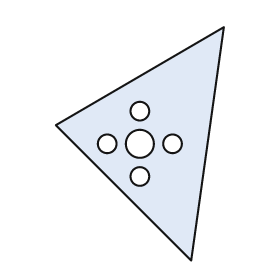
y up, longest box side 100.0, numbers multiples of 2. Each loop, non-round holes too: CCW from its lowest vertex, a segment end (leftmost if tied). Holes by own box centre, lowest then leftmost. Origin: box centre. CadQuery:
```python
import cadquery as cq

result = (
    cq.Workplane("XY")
    .moveTo(22.0, -50.0)
    .lineTo(36.0, 50.0)
    .lineTo(-36.0, 8.0)
    .close()
    .moveTo(0.0, -14.0)
    .circle(4.0)
    .moveTo(-14.0, 0.0)
    .circle(4.0)
    .moveTo(0.0, 0.0)
    .circle(6.0)
    .moveTo(14.0, 0.0)
    .circle(4.0)
    .moveTo(0.0, 14.0)
    .circle(4.0)
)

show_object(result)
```